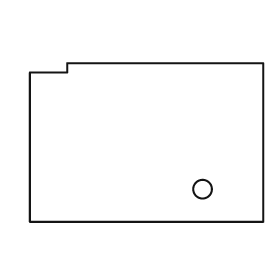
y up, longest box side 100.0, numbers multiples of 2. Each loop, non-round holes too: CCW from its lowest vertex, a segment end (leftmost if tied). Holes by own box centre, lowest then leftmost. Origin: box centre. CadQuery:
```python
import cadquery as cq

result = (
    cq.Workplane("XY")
    .moveTo(-50.0, -34.0)
    .lineTo(50.0, -34.0)
    .lineTo(50.0, 34.0)
    .lineTo(-34.0, 34.0)
    .lineTo(-34.0, 30.0)
    .lineTo(-50.0, 30.0)
    .close()
    .moveTo(24.0, -20.0)
    .circle(4.0)
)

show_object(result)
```